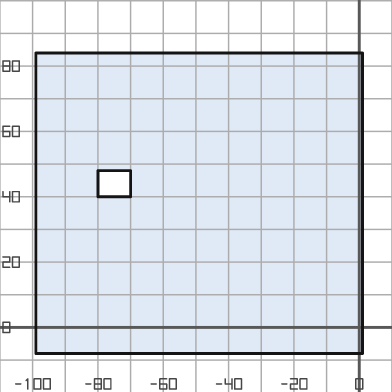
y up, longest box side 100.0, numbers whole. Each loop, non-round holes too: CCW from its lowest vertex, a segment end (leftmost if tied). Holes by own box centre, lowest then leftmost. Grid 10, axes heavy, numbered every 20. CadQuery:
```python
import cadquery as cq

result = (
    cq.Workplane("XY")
    .moveTo(-99.0, -8.0)
    .lineTo(1.0, -8.0)
    .lineTo(1.0, 84.0)
    .lineTo(-99.0, 84.0)
    .close()
    .moveTo(-80.0, 40.0)
    .lineTo(-70.0, 40.0)
    .lineTo(-70.0, 48.0)
    .lineTo(-80.0, 48.0)
    .close()
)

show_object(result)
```